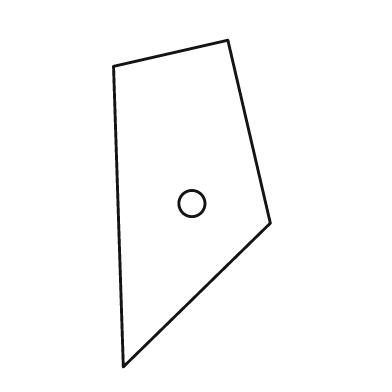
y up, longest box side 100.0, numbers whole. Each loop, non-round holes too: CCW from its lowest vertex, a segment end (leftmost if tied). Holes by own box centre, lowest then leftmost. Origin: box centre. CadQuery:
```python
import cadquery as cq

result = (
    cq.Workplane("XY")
    .moveTo(-21.0, -50.0)
    .lineTo(24.0, -6.0)
    .lineTo(11.0, 50.0)
    .lineTo(-24.0, 42.0)
    .close()
    .moveTo(0.0, 0.0)
    .circle(4.0)
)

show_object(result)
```